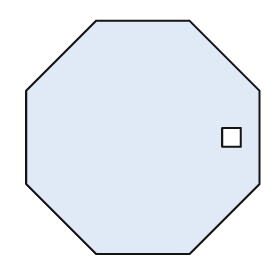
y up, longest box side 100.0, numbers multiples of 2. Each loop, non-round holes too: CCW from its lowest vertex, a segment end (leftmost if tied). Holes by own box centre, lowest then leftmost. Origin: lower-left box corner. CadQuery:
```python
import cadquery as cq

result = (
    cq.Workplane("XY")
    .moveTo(30.0, 0.0)
    .lineTo(70.0, 0.0)
    .lineTo(100.0, 30.0)
    .lineTo(100.0, 70.0)
    .lineTo(70.0, 100.0)
    .lineTo(30.0, 100.0)
    .lineTo(0.0, 70.0)
    .lineTo(0.0, 30.0)
    .close()
    .moveTo(84.0, 46.0)
    .lineTo(92.0, 46.0)
    .lineTo(92.0, 54.0)
    .lineTo(84.0, 54.0)
    .close()
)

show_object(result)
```